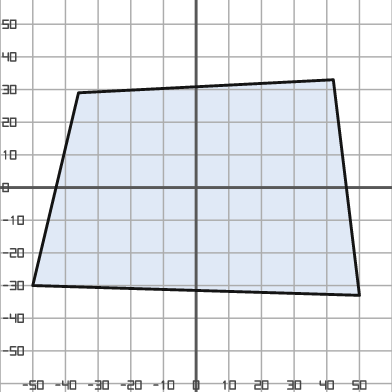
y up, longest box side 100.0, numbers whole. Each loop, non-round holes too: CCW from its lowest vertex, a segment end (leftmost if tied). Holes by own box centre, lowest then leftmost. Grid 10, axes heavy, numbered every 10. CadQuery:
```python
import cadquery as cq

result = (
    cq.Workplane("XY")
    .moveTo(50.0, -33.0)
    .lineTo(42.0, 33.0)
    .lineTo(-36.0, 29.0)
    .lineTo(-50.0, -30.0)
    .close()
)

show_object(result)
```